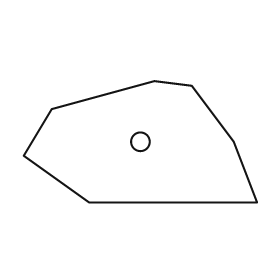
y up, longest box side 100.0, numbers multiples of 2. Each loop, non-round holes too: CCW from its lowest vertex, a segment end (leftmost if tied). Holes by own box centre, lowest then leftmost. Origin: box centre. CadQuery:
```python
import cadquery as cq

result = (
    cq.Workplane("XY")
    .moveTo(-22.0, -26.0)
    .lineTo(50.0, -26.0)
    .lineTo(40.0, 0.0)
    .lineTo(22.0, 24.0)
    .lineTo(6.0, 26.0)
    .lineTo(-38.0, 14.0)
    .lineTo(-50.0, -6.0)
    .close()
    .moveTo(0.0, 0.0)
    .circle(4.0)
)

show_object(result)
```